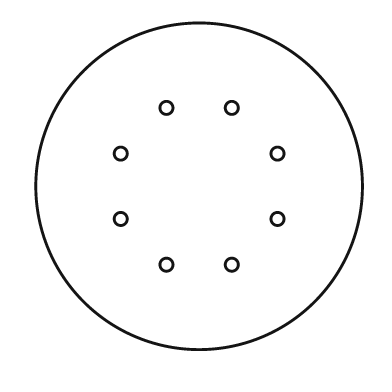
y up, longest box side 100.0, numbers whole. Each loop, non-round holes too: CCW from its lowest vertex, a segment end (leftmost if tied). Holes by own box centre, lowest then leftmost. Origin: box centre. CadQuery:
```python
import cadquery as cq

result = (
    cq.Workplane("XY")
    .moveTo(0.0, 0.0)
    .circle(50.0)
    .moveTo(-10.0, -24.0)
    .circle(2.0)
    .moveTo(10.0, -24.0)
    .circle(2.0)
    .moveTo(-24.0, -10.0)
    .circle(2.0)
    .moveTo(24.0, -10.0)
    .circle(2.0)
    .moveTo(-24.0, 10.0)
    .circle(2.0)
    .moveTo(24.0, 10.0)
    .circle(2.0)
    .moveTo(-10.0, 24.0)
    .circle(2.0)
    .moveTo(10.0, 24.0)
    .circle(2.0)
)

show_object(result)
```